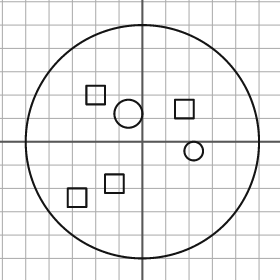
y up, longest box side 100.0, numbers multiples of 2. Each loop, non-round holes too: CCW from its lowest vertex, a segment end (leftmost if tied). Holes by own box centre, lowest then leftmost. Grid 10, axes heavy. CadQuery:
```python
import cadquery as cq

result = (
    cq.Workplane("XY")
    .moveTo(0.0, 0.0)
    .circle(50.0)
    .moveTo(-32.0, -28.0)
    .lineTo(-24.0, -28.0)
    .lineTo(-24.0, -20.0)
    .lineTo(-32.0, -20.0)
    .close()
    .moveTo(-16.0, -22.0)
    .lineTo(-8.0, -22.0)
    .lineTo(-8.0, -14.0)
    .lineTo(-16.0, -14.0)
    .close()
    .moveTo(22.0, -4.0)
    .circle(4.0)
    .moveTo(-6.0, 12.0)
    .circle(6.0)
    .moveTo(14.0, 10.0)
    .lineTo(22.0, 10.0)
    .lineTo(22.0, 18.0)
    .lineTo(14.0, 18.0)
    .close()
    .moveTo(-24.0, 16.0)
    .lineTo(-16.0, 16.0)
    .lineTo(-16.0, 24.0)
    .lineTo(-24.0, 24.0)
    .close()
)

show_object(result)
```